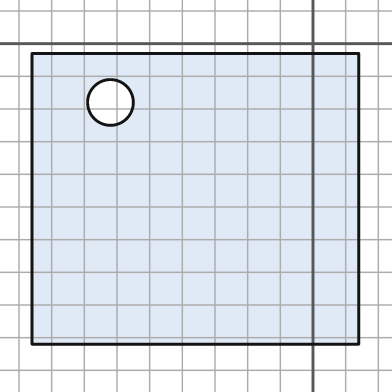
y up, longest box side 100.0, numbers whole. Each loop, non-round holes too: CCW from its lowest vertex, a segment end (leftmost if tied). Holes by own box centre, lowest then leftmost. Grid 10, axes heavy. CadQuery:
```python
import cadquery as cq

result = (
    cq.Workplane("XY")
    .moveTo(-86.0, -92.0)
    .lineTo(14.0, -92.0)
    .lineTo(14.0, -3.0)
    .lineTo(-86.0, -3.0)
    .close()
    .moveTo(-62.0, -18.0)
    .circle(7.0)
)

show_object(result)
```